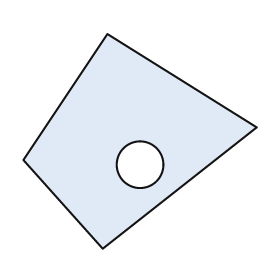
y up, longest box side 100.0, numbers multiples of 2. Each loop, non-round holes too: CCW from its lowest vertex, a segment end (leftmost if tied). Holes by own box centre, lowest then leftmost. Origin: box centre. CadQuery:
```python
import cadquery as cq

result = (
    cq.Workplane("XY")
    .moveTo(-16.0, -46.0)
    .lineTo(50.0, 6.0)
    .lineTo(-14.0, 46.0)
    .lineTo(-50.0, -8.0)
    .close()
    .moveTo(0.0, -10.0)
    .circle(10.0)
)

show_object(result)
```